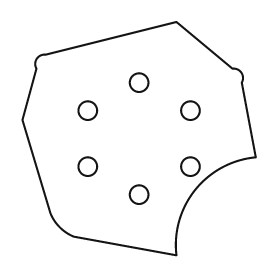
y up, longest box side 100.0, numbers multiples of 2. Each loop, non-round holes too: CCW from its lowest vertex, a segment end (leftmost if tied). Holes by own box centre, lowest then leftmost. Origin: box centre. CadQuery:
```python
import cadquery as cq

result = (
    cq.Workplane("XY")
    .moveTo(16.0, -50.0)
    .threePointArc((24.0, -22.0), (50.0, -8.0))
    .lineTo(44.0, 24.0)
    .threePointArc((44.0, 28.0), (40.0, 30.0))
    .lineTo(16.0, 50.0)
    .lineTo(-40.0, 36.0)
    .threePointArc((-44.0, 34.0), (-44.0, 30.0))
    .lineTo(-50.0, 8.0)
    .lineTo(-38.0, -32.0)
    .threePointArc((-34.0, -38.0), (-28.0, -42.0))
    .close()
    .moveTo(0.0, -24.0)
    .circle(4.0)
    .moveTo(-22.0, -12.0)
    .circle(4.0)
    .moveTo(22.0, -12.0)
    .circle(4.0)
    .moveTo(-22.0, 12.0)
    .circle(4.0)
    .moveTo(22.0, 12.0)
    .circle(4.0)
    .moveTo(0.0, 24.0)
    .circle(4.0)
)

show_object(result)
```